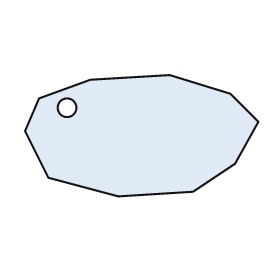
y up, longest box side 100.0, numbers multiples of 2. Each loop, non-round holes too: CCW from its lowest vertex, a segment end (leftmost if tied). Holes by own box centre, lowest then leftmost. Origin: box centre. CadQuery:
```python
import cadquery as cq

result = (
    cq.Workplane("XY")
    .moveTo(-10.0, -26.0)
    .lineTo(22.0, -24.0)
    .lineTo(40.0, -12.0)
    .lineTo(50.0, 6.0)
    .lineTo(38.0, 18.0)
    .lineTo(12.0, 26.0)
    .lineTo(-22.0, 24.0)
    .lineTo(-44.0, 16.0)
    .lineTo(-50.0, 2.0)
    .lineTo(-40.0, -18.0)
    .close()
    .moveTo(-32.0, 12.0)
    .circle(4.0)
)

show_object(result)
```